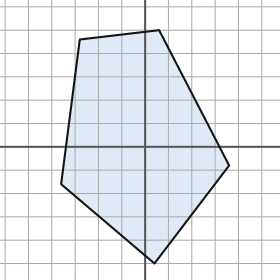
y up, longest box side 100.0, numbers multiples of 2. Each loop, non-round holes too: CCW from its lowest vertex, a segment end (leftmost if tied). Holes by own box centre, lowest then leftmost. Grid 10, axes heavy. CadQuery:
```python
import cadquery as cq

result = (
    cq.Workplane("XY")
    .moveTo(4.0, -50.0)
    .lineTo(36.0, -8.0)
    .lineTo(6.0, 50.0)
    .lineTo(-28.0, 46.0)
    .lineTo(-36.0, -16.0)
    .close()
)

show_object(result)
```